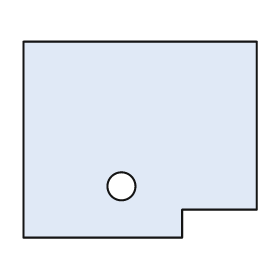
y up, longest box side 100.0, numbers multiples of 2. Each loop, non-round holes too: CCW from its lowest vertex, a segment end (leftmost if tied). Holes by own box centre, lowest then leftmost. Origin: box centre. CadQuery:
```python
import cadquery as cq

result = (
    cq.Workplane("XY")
    .moveTo(-50.0, -42.0)
    .lineTo(18.0, -42.0)
    .lineTo(18.0, -30.0)
    .lineTo(50.0, -30.0)
    .lineTo(50.0, 42.0)
    .lineTo(-50.0, 42.0)
    .close()
    .moveTo(-8.0, -20.0)
    .circle(6.0)
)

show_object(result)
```